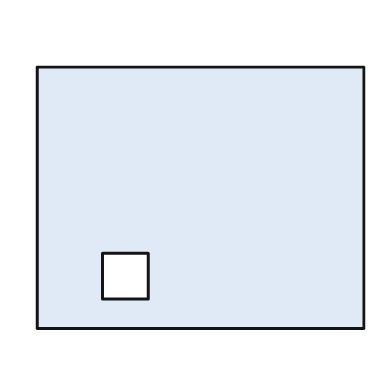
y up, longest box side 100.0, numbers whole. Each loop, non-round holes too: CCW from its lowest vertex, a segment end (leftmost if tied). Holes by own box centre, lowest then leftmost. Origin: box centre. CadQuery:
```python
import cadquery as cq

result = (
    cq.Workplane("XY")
    .moveTo(-50.0, -40.0)
    .lineTo(50.0, -40.0)
    .lineTo(50.0, 40.0)
    .lineTo(-50.0, 40.0)
    .close()
    .moveTo(-30.0, -31.0)
    .lineTo(-16.0, -31.0)
    .lineTo(-16.0, -17.0)
    .lineTo(-30.0, -17.0)
    .close()
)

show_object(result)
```